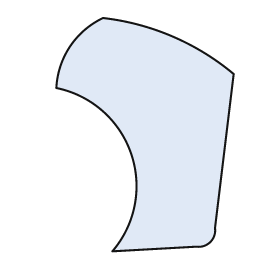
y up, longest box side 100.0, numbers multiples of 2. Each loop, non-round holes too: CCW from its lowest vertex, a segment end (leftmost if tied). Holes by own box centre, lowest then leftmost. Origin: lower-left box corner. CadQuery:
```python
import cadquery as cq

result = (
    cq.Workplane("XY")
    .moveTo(24.0, 0.0)
    .lineTo(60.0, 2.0)
    .threePointArc((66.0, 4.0), (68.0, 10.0))
    .lineTo(76.0, 76.0)
    .threePointArc((50.0, 92.0), (20.0, 100.0))
    .threePointArc((6.0, 88.0), (0.0, 70.0))
    .threePointArc((32.0, 42.0), (24.0, 0.0))
    .close()
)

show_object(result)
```